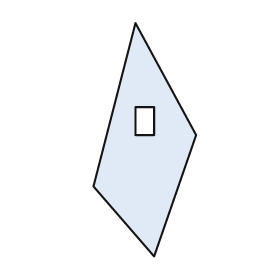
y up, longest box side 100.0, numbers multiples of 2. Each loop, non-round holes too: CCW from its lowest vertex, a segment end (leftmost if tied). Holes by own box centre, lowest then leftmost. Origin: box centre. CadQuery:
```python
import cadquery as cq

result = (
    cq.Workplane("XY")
    .moveTo(4.0, -50.0)
    .lineTo(22.0, 2.0)
    .lineTo(-4.0, 50.0)
    .lineTo(-22.0, -20.0)
    .close()
    .moveTo(-4.0, 2.0)
    .lineTo(4.0, 2.0)
    .lineTo(4.0, 14.0)
    .lineTo(-4.0, 14.0)
    .close()
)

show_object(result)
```